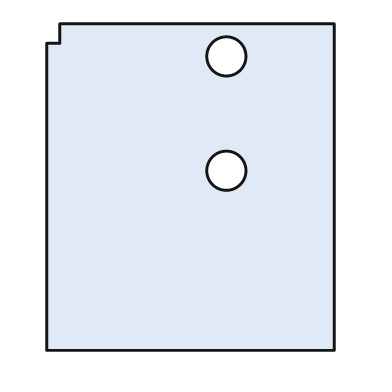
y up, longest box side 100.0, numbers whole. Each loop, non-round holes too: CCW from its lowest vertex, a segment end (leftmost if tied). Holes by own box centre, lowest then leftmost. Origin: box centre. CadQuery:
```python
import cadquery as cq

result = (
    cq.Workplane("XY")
    .moveTo(-44.0, -50.0)
    .lineTo(44.0, -50.0)
    .lineTo(44.0, 50.0)
    .lineTo(-40.0, 50.0)
    .lineTo(-40.0, 44.0)
    .lineTo(-44.0, 44.0)
    .close()
    .moveTo(11.0, 5.0)
    .circle(6.0)
    .moveTo(11.0, 40.0)
    .circle(6.0)
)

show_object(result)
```